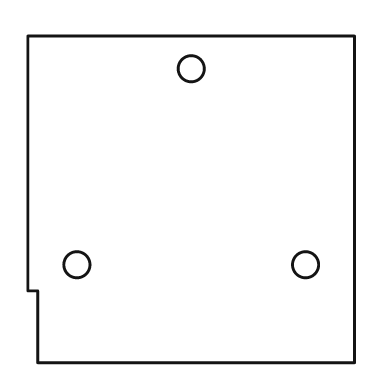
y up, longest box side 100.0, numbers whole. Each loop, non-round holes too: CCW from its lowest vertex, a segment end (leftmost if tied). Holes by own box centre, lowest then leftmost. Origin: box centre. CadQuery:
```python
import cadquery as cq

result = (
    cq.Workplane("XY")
    .moveTo(-47.0, -50.0)
    .lineTo(50.0, -50.0)
    .lineTo(50.0, 50.0)
    .lineTo(-50.0, 50.0)
    .lineTo(-50.0, -28.0)
    .lineTo(-47.0, -28.0)
    .close()
    .moveTo(-35.0, -20.0)
    .circle(4.0)
    .moveTo(35.0, -20.0)
    .circle(4.0)
    .moveTo(0.0, 40.0)
    .circle(4.0)
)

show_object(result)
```